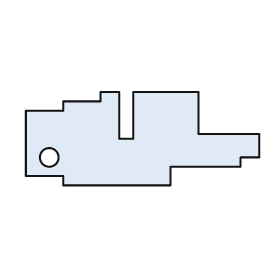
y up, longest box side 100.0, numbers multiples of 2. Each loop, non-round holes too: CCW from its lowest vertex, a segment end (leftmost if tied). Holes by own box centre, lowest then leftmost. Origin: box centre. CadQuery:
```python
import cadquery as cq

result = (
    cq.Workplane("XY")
    .moveTo(-34.0, -20.0)
    .lineTo(12.0, -20.0)
    .lineTo(12.0, -12.0)
    .lineTo(42.0, -12.0)
    .lineTo(42.0, -8.0)
    .lineTo(50.0, -8.0)
    .lineTo(50.0, 2.0)
    .lineTo(24.0, 2.0)
    .lineTo(24.0, 20.0)
    .lineTo(-4.0, 20.0)
    .lineTo(-4.0, 0.0)
    .lineTo(-10.0, 0.0)
    .lineTo(-10.0, 20.0)
    .lineTo(-18.0, 20.0)
    .lineTo(-18.0, 16.0)
    .lineTo(-34.0, 16.0)
    .lineTo(-34.0, 12.0)
    .lineTo(-50.0, 12.0)
    .lineTo(-50.0, -16.0)
    .lineTo(-34.0, -16.0)
    .close()
    .moveTo(-40.0, -8.0)
    .circle(4.0)
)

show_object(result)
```